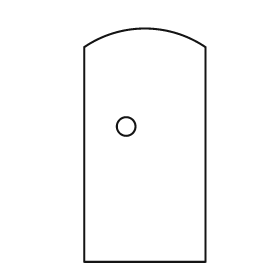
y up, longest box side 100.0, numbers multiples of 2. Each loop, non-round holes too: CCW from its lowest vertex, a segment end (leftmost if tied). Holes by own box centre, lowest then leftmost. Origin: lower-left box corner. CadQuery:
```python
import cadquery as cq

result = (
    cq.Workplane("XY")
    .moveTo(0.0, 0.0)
    .lineTo(52.0, 0.0)
    .lineTo(52.0, 92.0)
    .threePointArc((26.0, 100.0), (0.0, 92.0))
    .close()
    .moveTo(18.0, 58.0)
    .circle(4.0)
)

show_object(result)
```